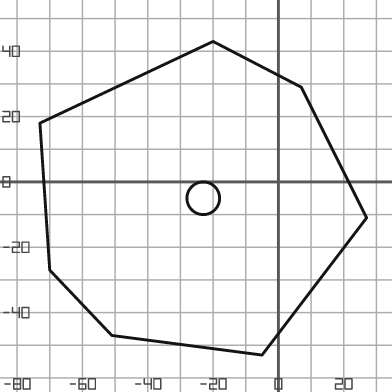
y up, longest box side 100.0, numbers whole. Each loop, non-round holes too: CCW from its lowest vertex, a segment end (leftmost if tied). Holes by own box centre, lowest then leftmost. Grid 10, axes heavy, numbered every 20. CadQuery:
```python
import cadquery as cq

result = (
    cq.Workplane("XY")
    .moveTo(-5.0, -53.0)
    .lineTo(27.0, -11.0)
    .lineTo(7.0, 29.0)
    .lineTo(-20.0, 43.0)
    .lineTo(-73.0, 18.0)
    .lineTo(-70.0, -27.0)
    .lineTo(-51.0, -47.0)
    .close()
    .moveTo(-23.0, -5.0)
    .circle(5.0)
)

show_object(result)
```